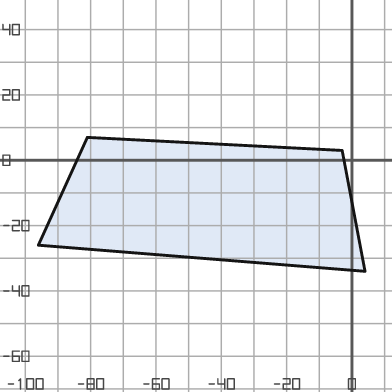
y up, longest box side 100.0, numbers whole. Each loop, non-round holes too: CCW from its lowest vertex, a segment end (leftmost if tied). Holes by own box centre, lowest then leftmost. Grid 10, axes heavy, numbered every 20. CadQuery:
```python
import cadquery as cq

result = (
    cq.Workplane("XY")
    .moveTo(4.0, -34.0)
    .lineTo(-3.0, 3.0)
    .lineTo(-81.0, 7.0)
    .lineTo(-96.0, -26.0)
    .close()
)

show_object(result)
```